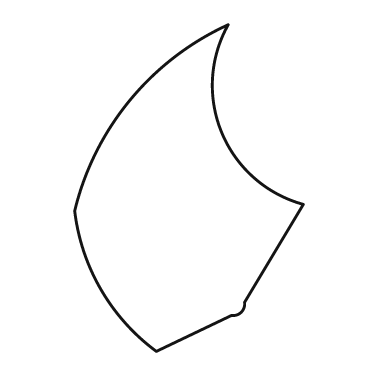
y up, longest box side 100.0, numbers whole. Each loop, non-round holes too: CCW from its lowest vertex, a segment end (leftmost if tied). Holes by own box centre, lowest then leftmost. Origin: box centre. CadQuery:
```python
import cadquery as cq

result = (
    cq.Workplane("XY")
    .moveTo(-10.0, -50.0)
    .lineTo(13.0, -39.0)
    .threePointArc((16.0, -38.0), (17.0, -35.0))
    .lineTo(35.0, -5.0)
    .threePointArc((10.0, 17.0), (12.0, 50.0))
    .threePointArc((-18.0, 27.0), (-35.0, -7.0))
    .threePointArc((-27.0, -31.0), (-10.0, -50.0))
    .close()
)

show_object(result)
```